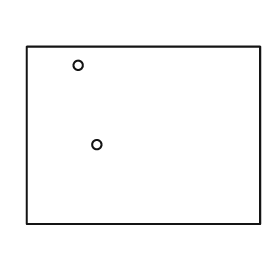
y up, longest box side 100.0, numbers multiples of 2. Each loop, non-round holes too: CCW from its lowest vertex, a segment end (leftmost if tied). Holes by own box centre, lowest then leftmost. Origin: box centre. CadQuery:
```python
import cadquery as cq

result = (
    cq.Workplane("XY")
    .moveTo(-50.0, -38.0)
    .lineTo(50.0, -38.0)
    .lineTo(50.0, 38.0)
    .lineTo(-50.0, 38.0)
    .close()
    .moveTo(-20.0, -4.0)
    .circle(2.0)
    .moveTo(-28.0, 30.0)
    .circle(2.0)
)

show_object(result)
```